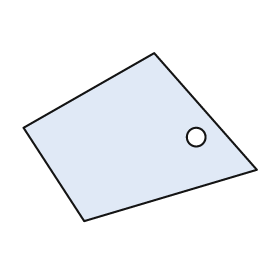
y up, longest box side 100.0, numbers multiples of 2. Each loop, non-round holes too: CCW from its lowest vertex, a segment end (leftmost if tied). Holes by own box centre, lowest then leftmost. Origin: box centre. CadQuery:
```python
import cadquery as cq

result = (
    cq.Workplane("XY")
    .moveTo(-24.0, -36.0)
    .lineTo(50.0, -14.0)
    .lineTo(6.0, 36.0)
    .lineTo(-50.0, 4.0)
    .close()
    .moveTo(24.0, 0.0)
    .circle(4.0)
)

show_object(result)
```